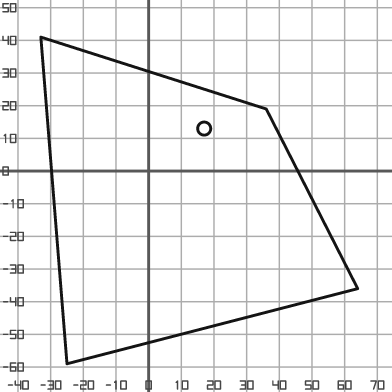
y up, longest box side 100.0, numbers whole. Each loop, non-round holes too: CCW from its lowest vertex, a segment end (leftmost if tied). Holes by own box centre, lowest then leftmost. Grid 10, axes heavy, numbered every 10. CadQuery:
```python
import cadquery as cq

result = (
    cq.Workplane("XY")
    .moveTo(-25.0, -59.0)
    .lineTo(64.0, -36.0)
    .lineTo(36.0, 19.0)
    .lineTo(-33.0, 41.0)
    .close()
    .moveTo(17.0, 13.0)
    .circle(2.0)
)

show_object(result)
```